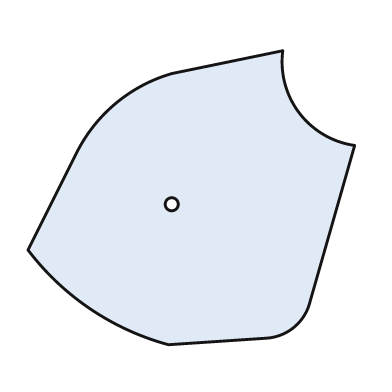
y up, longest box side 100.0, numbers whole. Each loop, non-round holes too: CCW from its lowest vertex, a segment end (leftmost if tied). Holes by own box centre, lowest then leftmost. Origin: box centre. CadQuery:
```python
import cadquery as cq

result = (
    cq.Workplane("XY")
    .moveTo(-7.0, -45.0)
    .lineTo(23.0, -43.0)
    .threePointArc((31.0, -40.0), (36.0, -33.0))
    .lineTo(50.0, 16.0)
    .threePointArc((33.0, 26.0), (28.0, 45.0))
    .lineTo(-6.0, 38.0)
    .threePointArc((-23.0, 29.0), (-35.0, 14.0))
    .lineTo(-50.0, -16.0)
    .threePointArc((-31.0, -34.0), (-7.0, -45.0))
    .close()
    .moveTo(-6.0, -2.0)
    .circle(2.0)
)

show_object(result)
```